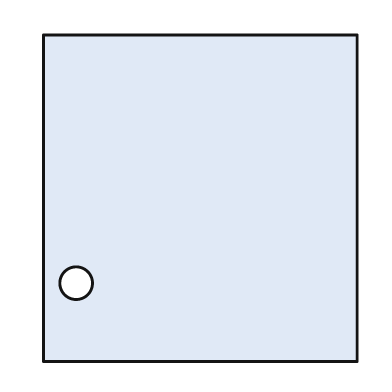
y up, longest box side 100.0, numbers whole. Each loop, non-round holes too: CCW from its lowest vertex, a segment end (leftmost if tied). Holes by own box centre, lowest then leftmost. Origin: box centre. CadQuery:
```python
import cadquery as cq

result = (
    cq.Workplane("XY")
    .moveTo(-48.0, -50.0)
    .lineTo(48.0, -50.0)
    .lineTo(48.0, 50.0)
    .lineTo(-48.0, 50.0)
    .close()
    .moveTo(-38.0, -26.0)
    .circle(5.0)
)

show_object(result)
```